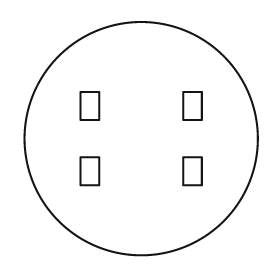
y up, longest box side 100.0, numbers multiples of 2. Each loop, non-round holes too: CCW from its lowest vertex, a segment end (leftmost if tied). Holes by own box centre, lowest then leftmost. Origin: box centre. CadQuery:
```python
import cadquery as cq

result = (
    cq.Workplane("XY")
    .moveTo(0.0, 0.0)
    .circle(50.0)
    .moveTo(-26.0, -20.0)
    .lineTo(-18.0, -20.0)
    .lineTo(-18.0, -8.0)
    .lineTo(-26.0, -8.0)
    .close()
    .moveTo(18.0, -20.0)
    .lineTo(26.0, -20.0)
    .lineTo(26.0, -8.0)
    .lineTo(18.0, -8.0)
    .close()
    .moveTo(-26.0, 8.0)
    .lineTo(-18.0, 8.0)
    .lineTo(-18.0, 20.0)
    .lineTo(-26.0, 20.0)
    .close()
    .moveTo(18.0, 8.0)
    .lineTo(26.0, 8.0)
    .lineTo(26.0, 20.0)
    .lineTo(18.0, 20.0)
    .close()
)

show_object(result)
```